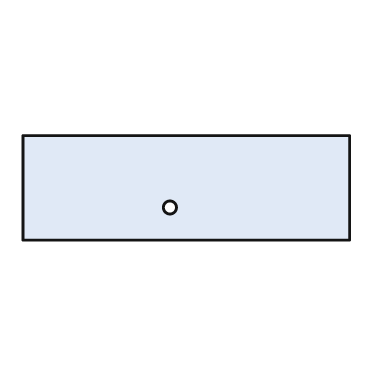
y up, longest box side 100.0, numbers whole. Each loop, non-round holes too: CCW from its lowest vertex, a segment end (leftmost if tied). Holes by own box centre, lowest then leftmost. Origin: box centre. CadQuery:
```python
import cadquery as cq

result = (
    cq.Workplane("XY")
    .moveTo(-50.0, -16.0)
    .lineTo(50.0, -16.0)
    .lineTo(50.0, 16.0)
    .lineTo(-50.0, 16.0)
    .close()
    .moveTo(-5.0, -6.0)
    .circle(2.0)
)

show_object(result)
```